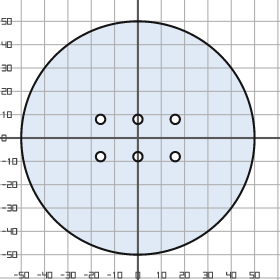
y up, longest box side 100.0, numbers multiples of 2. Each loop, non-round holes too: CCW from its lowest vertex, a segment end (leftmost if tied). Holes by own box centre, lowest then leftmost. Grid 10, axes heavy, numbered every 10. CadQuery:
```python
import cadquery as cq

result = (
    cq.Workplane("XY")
    .moveTo(0.0, 0.0)
    .circle(50.0)
    .moveTo(-16.0, -8.0)
    .circle(2.0)
    .moveTo(0.0, -8.0)
    .circle(2.0)
    .moveTo(16.0, -8.0)
    .circle(2.0)
    .moveTo(-16.0, 8.0)
    .circle(2.0)
    .moveTo(0.0, 8.0)
    .circle(2.0)
    .moveTo(16.0, 8.0)
    .circle(2.0)
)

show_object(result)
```